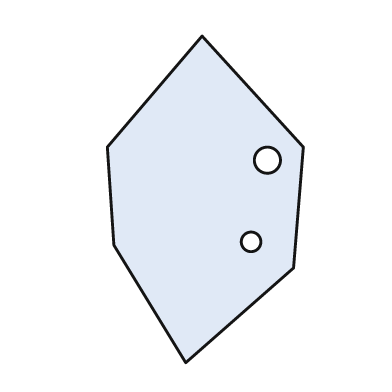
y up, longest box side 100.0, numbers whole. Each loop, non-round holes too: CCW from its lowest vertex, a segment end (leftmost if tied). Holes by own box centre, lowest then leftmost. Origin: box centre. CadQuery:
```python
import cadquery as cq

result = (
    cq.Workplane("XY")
    .moveTo(-6.0, -50.0)
    .lineTo(27.0, -21.0)
    .lineTo(30.0, 16.0)
    .lineTo(-1.0, 50.0)
    .lineTo(-30.0, 16.0)
    .lineTo(-28.0, -14.0)
    .close()
    .moveTo(14.0, -13.0)
    .circle(3.0)
    .moveTo(19.0, 12.0)
    .circle(4.0)
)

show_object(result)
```